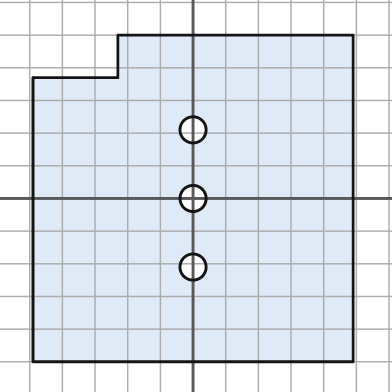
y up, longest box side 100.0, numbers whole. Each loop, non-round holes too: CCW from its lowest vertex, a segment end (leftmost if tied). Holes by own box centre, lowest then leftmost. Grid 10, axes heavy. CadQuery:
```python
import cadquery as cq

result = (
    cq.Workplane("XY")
    .moveTo(-49.0, -50.0)
    .lineTo(49.0, -50.0)
    .lineTo(49.0, 50.0)
    .lineTo(-23.0, 50.0)
    .lineTo(-23.0, 37.0)
    .lineTo(-49.0, 37.0)
    .close()
    .moveTo(0.0, -21.0)
    .circle(4.0)
    .moveTo(0.0, 0.0)
    .circle(4.0)
    .moveTo(0.0, 21.0)
    .circle(4.0)
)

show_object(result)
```